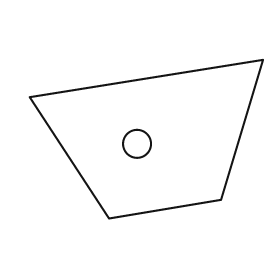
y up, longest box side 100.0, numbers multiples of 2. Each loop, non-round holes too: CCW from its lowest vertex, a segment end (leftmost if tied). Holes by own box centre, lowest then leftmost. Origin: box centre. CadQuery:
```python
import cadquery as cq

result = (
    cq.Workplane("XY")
    .moveTo(-16.0, -34.0)
    .lineTo(32.0, -26.0)
    .lineTo(50.0, 34.0)
    .lineTo(-50.0, 18.0)
    .close()
    .moveTo(-4.0, -2.0)
    .circle(6.0)
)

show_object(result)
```